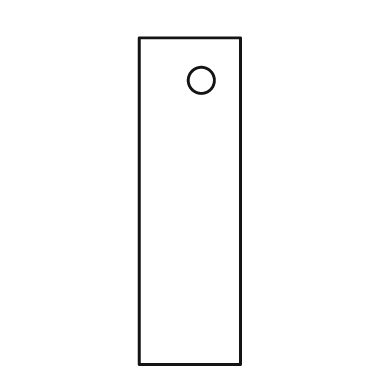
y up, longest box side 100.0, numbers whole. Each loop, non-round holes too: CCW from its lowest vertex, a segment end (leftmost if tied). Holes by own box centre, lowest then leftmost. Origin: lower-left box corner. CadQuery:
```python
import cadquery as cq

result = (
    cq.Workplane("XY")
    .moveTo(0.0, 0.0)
    .lineTo(31.0, 0.0)
    .lineTo(31.0, 100.0)
    .lineTo(0.0, 100.0)
    .close()
    .moveTo(19.0, 87.0)
    .circle(4.0)
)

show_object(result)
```